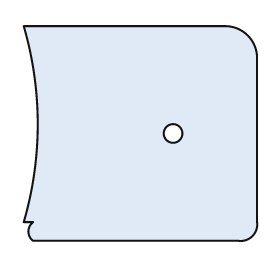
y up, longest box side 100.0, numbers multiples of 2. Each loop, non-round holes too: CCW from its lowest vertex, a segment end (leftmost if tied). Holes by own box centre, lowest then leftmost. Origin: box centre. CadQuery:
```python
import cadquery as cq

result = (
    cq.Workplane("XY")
    .moveTo(-46.0, -46.0)
    .lineTo(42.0, -46.0)
    .threePointArc((48.0, -44.0), (50.0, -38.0))
    .lineTo(50.0, 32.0)
    .threePointArc((46.0, 42.0), (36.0, 46.0))
    .lineTo(-50.0, 46.0)
    .threePointArc((-44.0, 4.0), (-50.0, -38.0))
    .lineTo(-46.0, -38.0)
    .threePointArc((-48.0, -42.0), (-46.0, -46.0))
    .close()
    .moveTo(14.0, 0.0)
    .circle(4.0)
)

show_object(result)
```